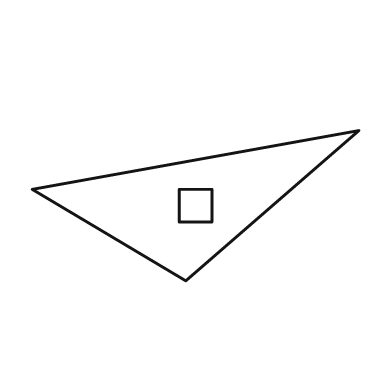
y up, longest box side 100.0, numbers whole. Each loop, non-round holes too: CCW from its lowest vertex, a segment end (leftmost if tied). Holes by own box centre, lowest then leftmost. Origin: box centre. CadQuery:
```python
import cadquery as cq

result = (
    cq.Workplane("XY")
    .moveTo(-3.0, -23.0)
    .lineTo(50.0, 23.0)
    .lineTo(-50.0, 5.0)
    .close()
    .moveTo(-5.0, -5.0)
    .lineTo(5.0, -5.0)
    .lineTo(5.0, 5.0)
    .lineTo(-5.0, 5.0)
    .close()
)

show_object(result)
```